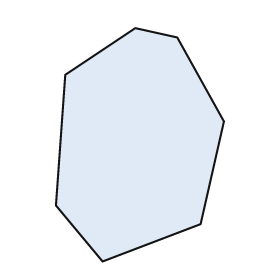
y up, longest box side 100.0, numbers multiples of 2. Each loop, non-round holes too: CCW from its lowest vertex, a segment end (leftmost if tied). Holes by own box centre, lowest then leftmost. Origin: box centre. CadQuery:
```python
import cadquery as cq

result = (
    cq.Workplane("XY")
    .moveTo(-16.0, -50.0)
    .lineTo(26.0, -34.0)
    .lineTo(36.0, 10.0)
    .lineTo(16.0, 46.0)
    .lineTo(-2.0, 50.0)
    .lineTo(-32.0, 30.0)
    .lineTo(-36.0, -26.0)
    .close()
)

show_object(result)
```